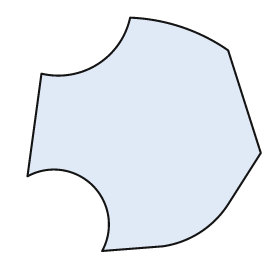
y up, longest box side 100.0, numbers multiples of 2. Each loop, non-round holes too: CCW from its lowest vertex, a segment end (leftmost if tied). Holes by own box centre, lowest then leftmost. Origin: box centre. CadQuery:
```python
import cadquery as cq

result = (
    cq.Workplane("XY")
    .moveTo(-18.0, -50.0)
    .lineTo(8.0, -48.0)
    .threePointArc((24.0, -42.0), (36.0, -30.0))
    .lineTo(50.0, -8.0)
    .lineTo(36.0, 36.0)
    .threePointArc((16.0, 46.0), (-6.0, 50.0))
    .threePointArc((-20.0, 30.0), (-44.0, 26.0))
    .lineTo(-50.0, -18.0)
    .threePointArc((-22.0, -22.0), (-18.0, -50.0))
    .close()
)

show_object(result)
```